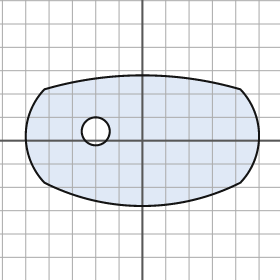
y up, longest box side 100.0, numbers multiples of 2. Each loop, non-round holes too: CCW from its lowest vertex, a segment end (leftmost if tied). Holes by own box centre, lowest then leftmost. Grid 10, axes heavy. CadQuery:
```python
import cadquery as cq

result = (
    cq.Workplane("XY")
    .moveTo(-42.0, -18.0)
    .threePointArc((0.0, -28.0), (42.0, -18.0))
    .threePointArc((50.0, 2.0), (42.0, 22.0))
    .threePointArc((0.0, 28.0), (-42.0, 22.0))
    .threePointArc((-50.0, 2.0), (-42.0, -18.0))
    .close()
    .moveTo(-20.0, 4.0)
    .circle(6.0)
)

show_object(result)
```